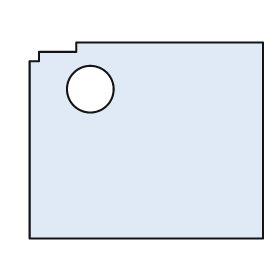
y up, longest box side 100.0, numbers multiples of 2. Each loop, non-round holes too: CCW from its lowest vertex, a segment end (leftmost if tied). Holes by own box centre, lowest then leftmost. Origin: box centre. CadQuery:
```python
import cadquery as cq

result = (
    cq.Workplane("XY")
    .moveTo(-50.0, -42.0)
    .lineTo(50.0, -42.0)
    .lineTo(50.0, 42.0)
    .lineTo(-30.0, 42.0)
    .lineTo(-30.0, 38.0)
    .lineTo(-46.0, 38.0)
    .lineTo(-46.0, 34.0)
    .lineTo(-50.0, 34.0)
    .close()
    .moveTo(-24.0, 22.0)
    .circle(10.0)
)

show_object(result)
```